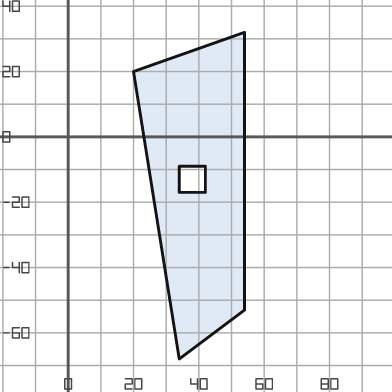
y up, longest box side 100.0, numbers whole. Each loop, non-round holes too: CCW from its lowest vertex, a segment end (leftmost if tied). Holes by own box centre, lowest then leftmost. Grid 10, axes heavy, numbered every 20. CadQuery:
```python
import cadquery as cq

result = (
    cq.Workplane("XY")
    .moveTo(34.0, -68.0)
    .lineTo(54.0, -53.0)
    .lineTo(54.0, 32.0)
    .lineTo(20.0, 20.0)
    .close()
    .moveTo(34.0, -17.0)
    .lineTo(42.0, -17.0)
    .lineTo(42.0, -9.0)
    .lineTo(34.0, -9.0)
    .close()
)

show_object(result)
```